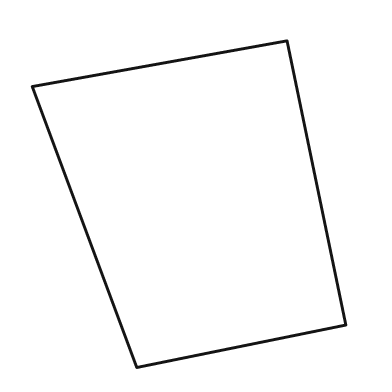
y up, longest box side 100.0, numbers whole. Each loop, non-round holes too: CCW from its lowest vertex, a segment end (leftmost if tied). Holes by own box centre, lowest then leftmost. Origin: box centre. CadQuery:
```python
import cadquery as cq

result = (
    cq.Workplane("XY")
    .moveTo(-16.0, -50.0)
    .lineTo(48.0, -37.0)
    .lineTo(30.0, 50.0)
    .lineTo(-48.0, 36.0)
    .close()
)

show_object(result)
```